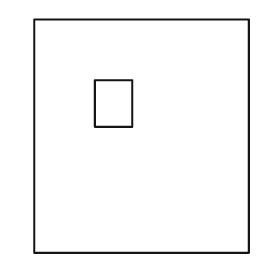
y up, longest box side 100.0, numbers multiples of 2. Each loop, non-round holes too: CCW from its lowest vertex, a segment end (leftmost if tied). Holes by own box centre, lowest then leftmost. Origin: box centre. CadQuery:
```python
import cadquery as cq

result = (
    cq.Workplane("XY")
    .moveTo(-46.0, -50.0)
    .lineTo(46.0, -50.0)
    .lineTo(46.0, 50.0)
    .lineTo(-46.0, 50.0)
    .close()
    .moveTo(-20.0, 4.0)
    .lineTo(-4.0, 4.0)
    .lineTo(-4.0, 24.0)
    .lineTo(-20.0, 24.0)
    .close()
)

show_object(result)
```